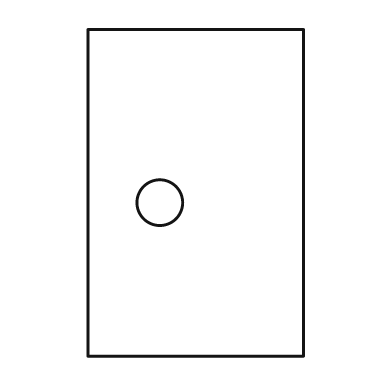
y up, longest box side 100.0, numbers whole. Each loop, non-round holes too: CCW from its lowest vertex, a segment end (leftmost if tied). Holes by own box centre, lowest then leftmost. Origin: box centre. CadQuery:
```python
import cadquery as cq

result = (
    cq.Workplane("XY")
    .moveTo(-33.0, -50.0)
    .lineTo(33.0, -50.0)
    .lineTo(33.0, 50.0)
    .lineTo(-33.0, 50.0)
    .close()
    .moveTo(-11.0, -3.0)
    .circle(7.0)
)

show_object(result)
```